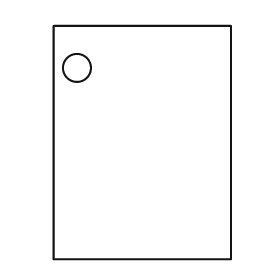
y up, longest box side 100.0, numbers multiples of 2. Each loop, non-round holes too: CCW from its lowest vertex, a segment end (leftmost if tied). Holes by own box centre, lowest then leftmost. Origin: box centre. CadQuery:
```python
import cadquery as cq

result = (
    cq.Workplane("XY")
    .moveTo(-38.0, -50.0)
    .lineTo(38.0, -50.0)
    .lineTo(38.0, 50.0)
    .lineTo(-38.0, 50.0)
    .close()
    .moveTo(-28.0, 32.0)
    .circle(6.0)
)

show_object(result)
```